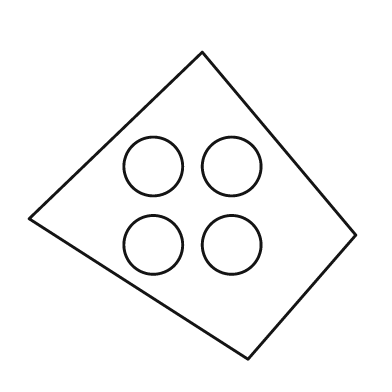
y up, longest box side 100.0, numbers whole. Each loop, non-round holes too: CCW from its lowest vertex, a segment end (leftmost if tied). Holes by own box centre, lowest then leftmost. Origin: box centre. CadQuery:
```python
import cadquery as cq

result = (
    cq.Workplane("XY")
    .moveTo(17.0, -47.0)
    .lineTo(50.0, -9.0)
    .lineTo(3.0, 47.0)
    .lineTo(-50.0, -4.0)
    .close()
    .moveTo(-12.0, -12.0)
    .circle(9.0)
    .moveTo(12.0, -12.0)
    .circle(9.0)
    .moveTo(-12.0, 12.0)
    .circle(9.0)
    .moveTo(12.0, 12.0)
    .circle(9.0)
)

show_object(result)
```